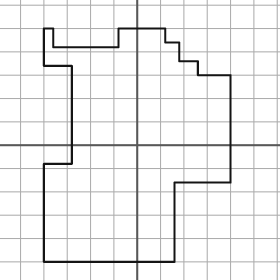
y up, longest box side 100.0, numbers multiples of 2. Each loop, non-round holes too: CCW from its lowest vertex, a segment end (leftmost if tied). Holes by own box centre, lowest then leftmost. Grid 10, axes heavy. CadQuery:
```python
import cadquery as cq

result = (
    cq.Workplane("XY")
    .moveTo(-40.0, -50.0)
    .lineTo(16.0, -50.0)
    .lineTo(16.0, -16.0)
    .lineTo(40.0, -16.0)
    .lineTo(40.0, 30.0)
    .lineTo(26.0, 30.0)
    .lineTo(26.0, 36.0)
    .lineTo(18.0, 36.0)
    .lineTo(18.0, 44.0)
    .lineTo(12.0, 44.0)
    .lineTo(12.0, 50.0)
    .lineTo(-8.0, 50.0)
    .lineTo(-8.0, 42.0)
    .lineTo(-36.0, 42.0)
    .lineTo(-36.0, 50.0)
    .lineTo(-40.0, 50.0)
    .lineTo(-40.0, 34.0)
    .lineTo(-28.0, 34.0)
    .lineTo(-28.0, -8.0)
    .lineTo(-40.0, -8.0)
    .close()
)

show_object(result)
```